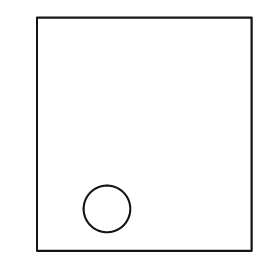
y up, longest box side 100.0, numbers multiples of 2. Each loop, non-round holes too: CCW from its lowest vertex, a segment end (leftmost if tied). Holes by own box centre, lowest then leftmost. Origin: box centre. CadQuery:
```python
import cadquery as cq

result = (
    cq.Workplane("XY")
    .moveTo(-46.0, -50.0)
    .lineTo(46.0, -50.0)
    .lineTo(46.0, 50.0)
    .lineTo(-46.0, 50.0)
    .close()
    .moveTo(-16.0, -32.0)
    .circle(10.0)
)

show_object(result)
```